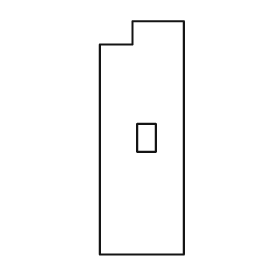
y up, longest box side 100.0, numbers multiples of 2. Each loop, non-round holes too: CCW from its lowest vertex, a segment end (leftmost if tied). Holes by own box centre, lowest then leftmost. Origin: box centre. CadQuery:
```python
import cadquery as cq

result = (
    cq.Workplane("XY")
    .moveTo(-18.0, -50.0)
    .lineTo(18.0, -50.0)
    .lineTo(18.0, 50.0)
    .lineTo(-4.0, 50.0)
    .lineTo(-4.0, 40.0)
    .lineTo(-18.0, 40.0)
    .close()
    .moveTo(-2.0, -6.0)
    .lineTo(6.0, -6.0)
    .lineTo(6.0, 6.0)
    .lineTo(-2.0, 6.0)
    .close()
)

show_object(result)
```